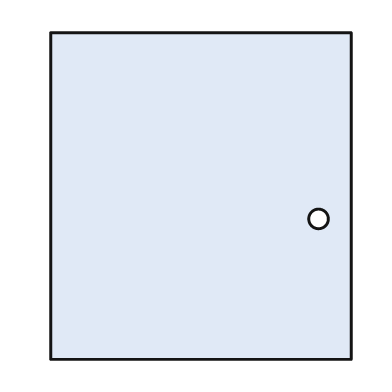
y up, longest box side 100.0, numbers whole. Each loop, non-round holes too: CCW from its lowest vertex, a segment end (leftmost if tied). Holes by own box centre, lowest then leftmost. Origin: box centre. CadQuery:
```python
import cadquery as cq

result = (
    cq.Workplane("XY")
    .moveTo(-46.0, -50.0)
    .lineTo(46.0, -50.0)
    .lineTo(46.0, 50.0)
    .lineTo(-46.0, 50.0)
    .close()
    .moveTo(36.0, -7.0)
    .circle(3.0)
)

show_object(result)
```